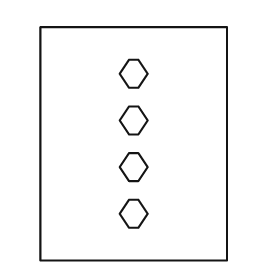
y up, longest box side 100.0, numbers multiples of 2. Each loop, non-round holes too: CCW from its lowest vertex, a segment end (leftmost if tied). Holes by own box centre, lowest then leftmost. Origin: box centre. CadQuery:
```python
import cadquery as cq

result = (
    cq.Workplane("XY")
    .moveTo(-40.0, -50.0)
    .lineTo(40.0, -50.0)
    .lineTo(40.0, 50.0)
    .lineTo(-40.0, 50.0)
    .close()
    .moveTo(-2.0, -36.0)
    .lineTo(2.0, -36.0)
    .lineTo(6.0, -30.0)
    .lineTo(2.0, -24.0)
    .lineTo(-2.0, -24.0)
    .lineTo(-6.0, -30.0)
    .close()
    .moveTo(-2.0, -16.0)
    .lineTo(2.0, -16.0)
    .lineTo(6.0, -10.0)
    .lineTo(2.0, -4.0)
    .lineTo(-2.0, -4.0)
    .lineTo(-6.0, -10.0)
    .close()
    .moveTo(-2.0, 4.0)
    .lineTo(2.0, 4.0)
    .lineTo(6.0, 10.0)
    .lineTo(2.0, 16.0)
    .lineTo(-2.0, 16.0)
    .lineTo(-6.0, 10.0)
    .close()
    .moveTo(-2.0, 24.0)
    .lineTo(2.0, 24.0)
    .lineTo(6.0, 30.0)
    .lineTo(2.0, 36.0)
    .lineTo(-2.0, 36.0)
    .lineTo(-6.0, 30.0)
    .close()
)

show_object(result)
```